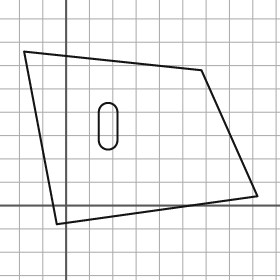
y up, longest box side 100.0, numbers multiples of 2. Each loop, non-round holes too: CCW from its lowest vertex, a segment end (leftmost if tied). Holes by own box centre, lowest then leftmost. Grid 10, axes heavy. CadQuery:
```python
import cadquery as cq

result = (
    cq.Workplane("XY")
    .moveTo(-4.0, -8.0)
    .lineTo(82.0, 4.0)
    .lineTo(58.0, 58.0)
    .lineTo(-18.0, 66.0)
    .close()
    .moveTo(14.0, 28.0)
    .threePointArc((18.0, 24.0), (22.0, 28.0))
    .lineTo(22.0, 40.0)
    .threePointArc((18.0, 44.0), (14.0, 40.0))
    .close()
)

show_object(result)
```